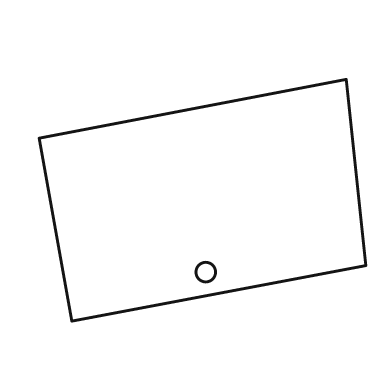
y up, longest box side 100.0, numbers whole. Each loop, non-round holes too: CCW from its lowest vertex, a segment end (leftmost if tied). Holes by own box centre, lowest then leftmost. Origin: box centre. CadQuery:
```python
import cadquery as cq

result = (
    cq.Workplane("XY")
    .moveTo(-40.0, -37.0)
    .lineTo(50.0, -20.0)
    .lineTo(44.0, 37.0)
    .lineTo(-50.0, 19.0)
    .close()
    .moveTo(1.0, -22.0)
    .circle(3.0)
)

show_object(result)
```